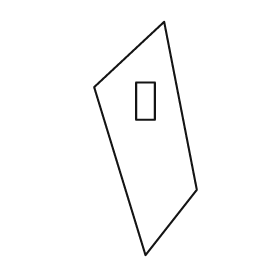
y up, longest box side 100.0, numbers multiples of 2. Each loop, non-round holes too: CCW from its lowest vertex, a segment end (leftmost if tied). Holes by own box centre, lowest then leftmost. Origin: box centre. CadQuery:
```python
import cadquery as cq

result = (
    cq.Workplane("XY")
    .moveTo(0.0, -50.0)
    .lineTo(22.0, -22.0)
    .lineTo(8.0, 50.0)
    .lineTo(-22.0, 22.0)
    .close()
    .moveTo(-4.0, 8.0)
    .lineTo(4.0, 8.0)
    .lineTo(4.0, 24.0)
    .lineTo(-4.0, 24.0)
    .close()
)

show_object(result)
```